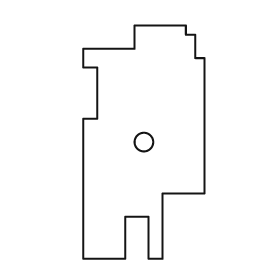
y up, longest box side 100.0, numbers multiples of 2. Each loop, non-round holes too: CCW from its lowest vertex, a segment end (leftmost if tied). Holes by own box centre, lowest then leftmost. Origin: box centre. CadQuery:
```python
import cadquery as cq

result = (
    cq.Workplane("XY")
    .moveTo(-26.0, -50.0)
    .lineTo(-8.0, -50.0)
    .lineTo(-8.0, -32.0)
    .lineTo(2.0, -32.0)
    .lineTo(2.0, -50.0)
    .lineTo(8.0, -50.0)
    .lineTo(8.0, -22.0)
    .lineTo(26.0, -22.0)
    .lineTo(26.0, 36.0)
    .lineTo(22.0, 36.0)
    .lineTo(22.0, 46.0)
    .lineTo(18.0, 46.0)
    .lineTo(18.0, 50.0)
    .lineTo(-4.0, 50.0)
    .lineTo(-4.0, 40.0)
    .lineTo(-26.0, 40.0)
    .lineTo(-26.0, 32.0)
    .lineTo(-20.0, 32.0)
    .lineTo(-20.0, 10.0)
    .lineTo(-26.0, 10.0)
    .close()
    .moveTo(0.0, 0.0)
    .circle(4.0)
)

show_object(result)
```